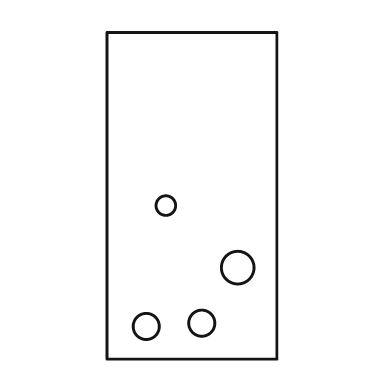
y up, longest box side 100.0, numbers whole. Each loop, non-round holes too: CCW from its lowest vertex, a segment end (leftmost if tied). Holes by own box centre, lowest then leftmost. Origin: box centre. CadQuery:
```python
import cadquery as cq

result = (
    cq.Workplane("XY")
    .moveTo(-26.0, -50.0)
    .lineTo(26.0, -50.0)
    .lineTo(26.0, 50.0)
    .lineTo(-26.0, 50.0)
    .close()
    .moveTo(-14.0, -40.0)
    .circle(4.0)
    .moveTo(3.0, -39.0)
    .circle(4.0)
    .moveTo(14.0, -22.0)
    .circle(5.0)
    .moveTo(-8.0, -3.0)
    .circle(3.0)
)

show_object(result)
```